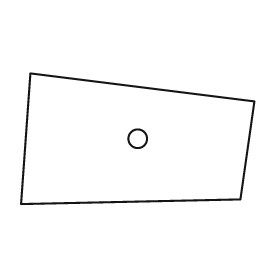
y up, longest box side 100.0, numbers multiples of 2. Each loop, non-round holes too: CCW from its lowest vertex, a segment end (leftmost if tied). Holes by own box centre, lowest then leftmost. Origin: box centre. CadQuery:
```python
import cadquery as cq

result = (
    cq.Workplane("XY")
    .moveTo(-50.0, -28.0)
    .lineTo(44.0, -26.0)
    .lineTo(50.0, 16.0)
    .lineTo(-46.0, 28.0)
    .close()
    .moveTo(0.0, 0.0)
    .circle(4.0)
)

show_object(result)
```